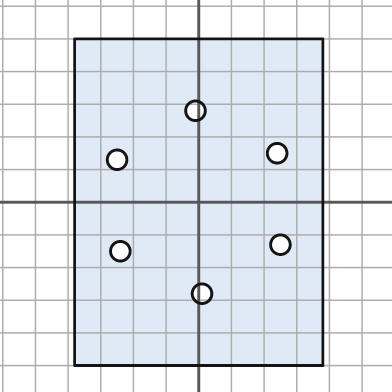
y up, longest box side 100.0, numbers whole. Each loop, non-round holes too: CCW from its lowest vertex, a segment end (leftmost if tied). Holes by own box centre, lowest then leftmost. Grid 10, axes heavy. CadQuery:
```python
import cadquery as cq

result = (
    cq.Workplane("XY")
    .moveTo(-38.0, -50.0)
    .lineTo(38.0, -50.0)
    .lineTo(38.0, 50.0)
    .lineTo(-38.0, 50.0)
    .close()
    .moveTo(1.0, -28.0)
    .circle(3.0)
    .moveTo(-24.0, -15.0)
    .circle(3.0)
    .moveTo(25.0, -13.0)
    .circle(3.0)
    .moveTo(-25.0, 13.0)
    .circle(3.0)
    .moveTo(24.0, 15.0)
    .circle(3.0)
    .moveTo(-1.0, 28.0)
    .circle(3.0)
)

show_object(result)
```